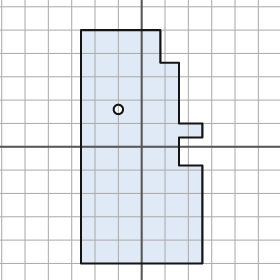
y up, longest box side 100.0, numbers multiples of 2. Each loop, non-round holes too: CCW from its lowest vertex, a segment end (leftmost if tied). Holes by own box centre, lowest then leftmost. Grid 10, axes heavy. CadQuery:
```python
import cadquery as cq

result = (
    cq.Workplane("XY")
    .moveTo(-26.0, -50.0)
    .lineTo(26.0, -50.0)
    .lineTo(26.0, -8.0)
    .lineTo(16.0, -8.0)
    .lineTo(16.0, 4.0)
    .lineTo(26.0, 4.0)
    .lineTo(26.0, 10.0)
    .lineTo(16.0, 10.0)
    .lineTo(16.0, 36.0)
    .lineTo(8.0, 36.0)
    .lineTo(8.0, 50.0)
    .lineTo(-26.0, 50.0)
    .close()
    .moveTo(-10.0, 16.0)
    .circle(2.0)
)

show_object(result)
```